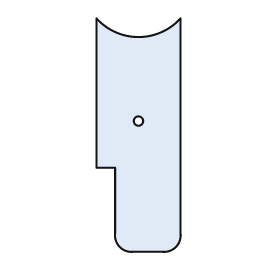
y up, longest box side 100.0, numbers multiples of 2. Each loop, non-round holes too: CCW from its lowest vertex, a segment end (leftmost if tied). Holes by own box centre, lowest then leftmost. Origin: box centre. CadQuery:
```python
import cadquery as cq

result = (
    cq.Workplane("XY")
    .moveTo(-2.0, -50.0)
    .lineTo(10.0, -50.0)
    .threePointArc((16.0, -48.0), (18.0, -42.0))
    .lineTo(18.0, 50.0)
    .threePointArc((0.0, 42.0), (-18.0, 50.0))
    .lineTo(-18.0, -14.0)
    .lineTo(-10.0, -14.0)
    .lineTo(-10.0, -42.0)
    .threePointArc((-8.0, -48.0), (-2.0, -50.0))
    .close()
    .moveTo(0.0, 6.0)
    .circle(2.0)
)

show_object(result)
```